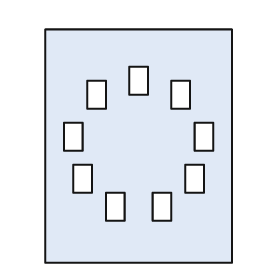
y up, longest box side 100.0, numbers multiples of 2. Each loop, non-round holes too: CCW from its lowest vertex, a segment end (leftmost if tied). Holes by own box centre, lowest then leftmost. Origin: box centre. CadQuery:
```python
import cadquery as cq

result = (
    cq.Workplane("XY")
    .moveTo(-40.0, -50.0)
    .lineTo(40.0, -50.0)
    .lineTo(40.0, 50.0)
    .lineTo(-40.0, 50.0)
    .close()
    .moveTo(-14.0, -32.0)
    .lineTo(-6.0, -32.0)
    .lineTo(-6.0, -20.0)
    .lineTo(-14.0, -20.0)
    .close()
    .moveTo(6.0, -32.0)
    .lineTo(14.0, -32.0)
    .lineTo(14.0, -20.0)
    .lineTo(6.0, -20.0)
    .close()
    .moveTo(-28.0, -20.0)
    .lineTo(-20.0, -20.0)
    .lineTo(-20.0, -8.0)
    .lineTo(-28.0, -8.0)
    .close()
    .moveTo(20.0, -20.0)
    .lineTo(28.0, -20.0)
    .lineTo(28.0, -8.0)
    .lineTo(20.0, -8.0)
    .close()
    .moveTo(-32.0, -2.0)
    .lineTo(-24.0, -2.0)
    .lineTo(-24.0, 10.0)
    .lineTo(-32.0, 10.0)
    .close()
    .moveTo(24.0, -2.0)
    .lineTo(32.0, -2.0)
    .lineTo(32.0, 10.0)
    .lineTo(24.0, 10.0)
    .close()
    .moveTo(-22.0, 16.0)
    .lineTo(-14.0, 16.0)
    .lineTo(-14.0, 28.0)
    .lineTo(-22.0, 28.0)
    .close()
    .moveTo(14.0, 16.0)
    .lineTo(22.0, 16.0)
    .lineTo(22.0, 28.0)
    .lineTo(14.0, 28.0)
    .close()
    .moveTo(-4.0, 22.0)
    .lineTo(4.0, 22.0)
    .lineTo(4.0, 34.0)
    .lineTo(-4.0, 34.0)
    .close()
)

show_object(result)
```